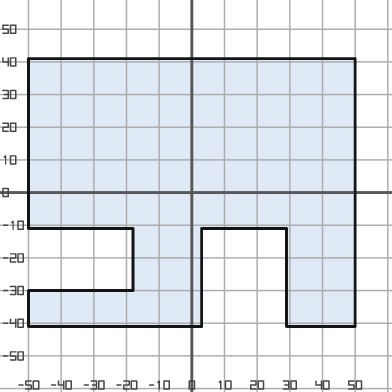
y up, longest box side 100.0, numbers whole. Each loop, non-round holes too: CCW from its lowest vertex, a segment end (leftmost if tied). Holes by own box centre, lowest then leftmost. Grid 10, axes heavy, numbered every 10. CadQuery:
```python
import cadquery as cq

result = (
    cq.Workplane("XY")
    .moveTo(-50.0, -41.0)
    .lineTo(3.0, -41.0)
    .lineTo(3.0, -11.0)
    .lineTo(29.0, -11.0)
    .lineTo(29.0, -41.0)
    .lineTo(50.0, -41.0)
    .lineTo(50.0, 41.0)
    .lineTo(-50.0, 41.0)
    .lineTo(-50.0, -11.0)
    .lineTo(-18.0, -11.0)
    .lineTo(-18.0, -30.0)
    .lineTo(-50.0, -30.0)
    .close()
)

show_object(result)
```